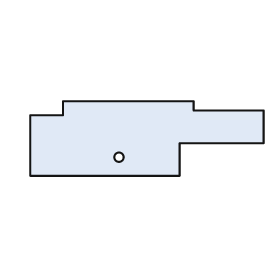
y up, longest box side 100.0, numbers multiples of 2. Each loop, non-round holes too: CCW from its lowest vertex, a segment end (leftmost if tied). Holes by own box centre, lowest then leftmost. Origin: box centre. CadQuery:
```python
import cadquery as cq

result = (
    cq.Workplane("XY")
    .moveTo(-50.0, -16.0)
    .lineTo(14.0, -16.0)
    .lineTo(14.0, -2.0)
    .lineTo(50.0, -2.0)
    .lineTo(50.0, 12.0)
    .lineTo(20.0, 12.0)
    .lineTo(20.0, 16.0)
    .lineTo(-36.0, 16.0)
    .lineTo(-36.0, 10.0)
    .lineTo(-50.0, 10.0)
    .close()
    .moveTo(-12.0, -8.0)
    .circle(2.0)
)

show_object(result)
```